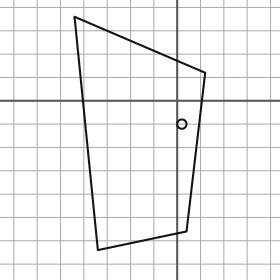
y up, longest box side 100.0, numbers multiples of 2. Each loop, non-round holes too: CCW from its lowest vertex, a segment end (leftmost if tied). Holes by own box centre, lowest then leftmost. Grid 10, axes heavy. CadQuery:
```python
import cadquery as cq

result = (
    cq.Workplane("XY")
    .moveTo(-34.0, -64.0)
    .lineTo(4.0, -56.0)
    .lineTo(12.0, 12.0)
    .lineTo(-44.0, 36.0)
    .close()
    .moveTo(2.0, -10.0)
    .circle(2.0)
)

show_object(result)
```